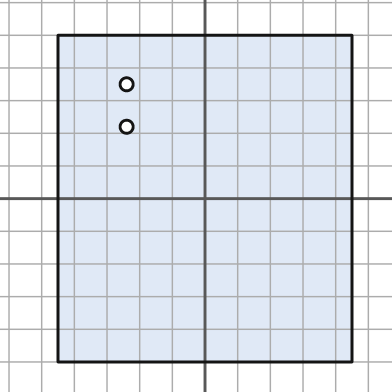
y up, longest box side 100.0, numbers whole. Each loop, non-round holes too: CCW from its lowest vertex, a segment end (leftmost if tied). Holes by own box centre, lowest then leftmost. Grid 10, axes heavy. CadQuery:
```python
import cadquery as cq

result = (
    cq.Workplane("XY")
    .moveTo(-45.0, -50.0)
    .lineTo(45.0, -50.0)
    .lineTo(45.0, 50.0)
    .lineTo(-45.0, 50.0)
    .close()
    .moveTo(-24.0, 22.0)
    .circle(2.0)
    .moveTo(-24.0, 35.0)
    .circle(2.0)
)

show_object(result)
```